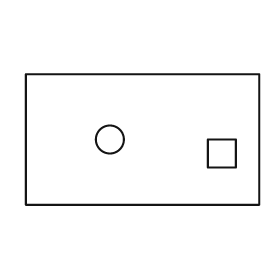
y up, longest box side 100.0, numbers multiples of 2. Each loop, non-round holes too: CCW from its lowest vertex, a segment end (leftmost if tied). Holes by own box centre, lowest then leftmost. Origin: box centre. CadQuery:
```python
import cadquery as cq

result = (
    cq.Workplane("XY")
    .moveTo(-50.0, -28.0)
    .lineTo(50.0, -28.0)
    .lineTo(50.0, 28.0)
    .lineTo(-50.0, 28.0)
    .close()
    .moveTo(28.0, -12.0)
    .lineTo(40.0, -12.0)
    .lineTo(40.0, 0.0)
    .lineTo(28.0, 0.0)
    .close()
    .moveTo(-14.0, 0.0)
    .circle(6.0)
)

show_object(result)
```